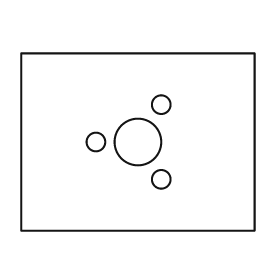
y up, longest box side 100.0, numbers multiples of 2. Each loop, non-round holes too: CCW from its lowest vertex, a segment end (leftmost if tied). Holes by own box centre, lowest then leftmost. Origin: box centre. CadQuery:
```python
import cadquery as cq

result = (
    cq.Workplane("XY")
    .moveTo(-50.0, -38.0)
    .lineTo(50.0, -38.0)
    .lineTo(50.0, 38.0)
    .lineTo(-50.0, 38.0)
    .close()
    .moveTo(10.0, -16.0)
    .circle(4.0)
    .moveTo(-18.0, 0.0)
    .circle(4.0)
    .moveTo(0.0, 0.0)
    .circle(10.0)
    .moveTo(10.0, 16.0)
    .circle(4.0)
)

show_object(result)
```